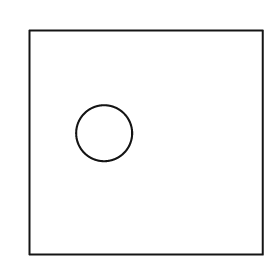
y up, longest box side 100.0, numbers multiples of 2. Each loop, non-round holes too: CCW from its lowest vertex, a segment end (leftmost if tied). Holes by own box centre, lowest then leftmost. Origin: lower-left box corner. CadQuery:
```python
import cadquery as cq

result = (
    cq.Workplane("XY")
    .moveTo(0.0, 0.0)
    .lineTo(100.0, 0.0)
    .lineTo(100.0, 96.0)
    .lineTo(0.0, 96.0)
    .close()
    .moveTo(32.0, 52.0)
    .circle(12.0)
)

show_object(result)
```